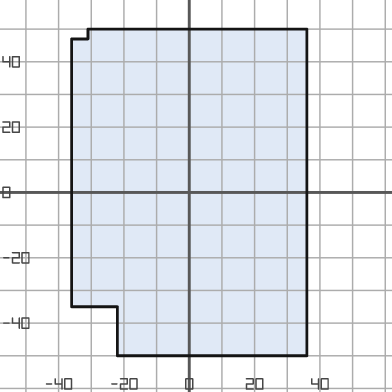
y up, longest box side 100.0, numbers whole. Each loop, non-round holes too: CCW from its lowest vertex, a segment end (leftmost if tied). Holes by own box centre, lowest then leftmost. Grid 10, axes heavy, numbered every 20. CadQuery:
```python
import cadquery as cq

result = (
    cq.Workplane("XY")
    .moveTo(-22.0, -50.0)
    .lineTo(36.0, -50.0)
    .lineTo(36.0, 50.0)
    .lineTo(-31.0, 50.0)
    .lineTo(-31.0, 47.0)
    .lineTo(-36.0, 47.0)
    .lineTo(-36.0, -35.0)
    .lineTo(-22.0, -35.0)
    .close()
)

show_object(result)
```